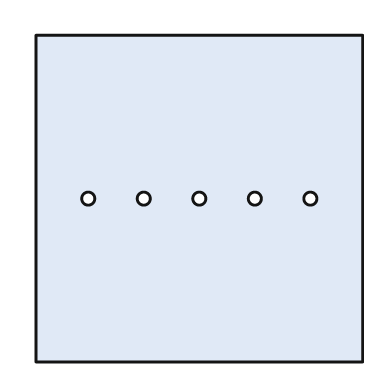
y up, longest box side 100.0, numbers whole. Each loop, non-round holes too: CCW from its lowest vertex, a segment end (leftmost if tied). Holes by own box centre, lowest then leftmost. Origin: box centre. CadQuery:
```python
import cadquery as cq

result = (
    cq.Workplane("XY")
    .moveTo(-50.0, -50.0)
    .lineTo(50.0, -50.0)
    .lineTo(50.0, 50.0)
    .lineTo(-50.0, 50.0)
    .close()
    .moveTo(-34.0, 0.0)
    .circle(2.0)
    .moveTo(-17.0, 0.0)
    .circle(2.0)
    .moveTo(0.0, 0.0)
    .circle(2.0)
    .moveTo(17.0, 0.0)
    .circle(2.0)
    .moveTo(34.0, 0.0)
    .circle(2.0)
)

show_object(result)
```